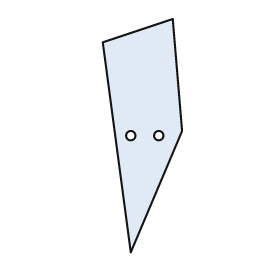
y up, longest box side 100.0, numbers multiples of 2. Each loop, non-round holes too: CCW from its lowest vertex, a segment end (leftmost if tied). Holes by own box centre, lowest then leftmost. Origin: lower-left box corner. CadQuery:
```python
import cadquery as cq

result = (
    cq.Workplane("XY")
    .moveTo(12.0, 0.0)
    .lineTo(34.0, 52.0)
    .lineTo(30.0, 100.0)
    .lineTo(0.0, 90.0)
    .close()
    .moveTo(12.0, 50.0)
    .circle(2.0)
    .moveTo(24.0, 50.0)
    .circle(2.0)
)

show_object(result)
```